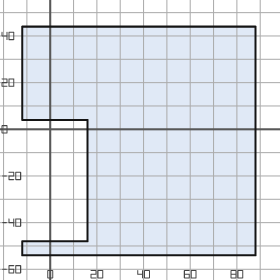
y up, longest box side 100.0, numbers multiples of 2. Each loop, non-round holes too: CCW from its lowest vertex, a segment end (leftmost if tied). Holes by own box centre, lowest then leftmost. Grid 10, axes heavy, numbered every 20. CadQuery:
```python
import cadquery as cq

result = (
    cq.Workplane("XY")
    .moveTo(-12.0, -54.0)
    .lineTo(88.0, -54.0)
    .lineTo(88.0, 44.0)
    .lineTo(-12.0, 44.0)
    .lineTo(-12.0, 4.0)
    .lineTo(16.0, 4.0)
    .lineTo(16.0, -48.0)
    .lineTo(-12.0, -48.0)
    .close()
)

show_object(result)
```